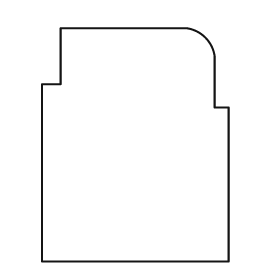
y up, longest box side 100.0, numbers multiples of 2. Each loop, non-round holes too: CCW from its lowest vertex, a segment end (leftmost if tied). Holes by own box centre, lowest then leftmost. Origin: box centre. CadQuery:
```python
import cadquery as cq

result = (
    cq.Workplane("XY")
    .moveTo(-40.0, -50.0)
    .lineTo(40.0, -50.0)
    .lineTo(40.0, 16.0)
    .lineTo(34.0, 16.0)
    .lineTo(34.0, 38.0)
    .threePointArc((30.0, 46.0), (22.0, 50.0))
    .lineTo(-32.0, 50.0)
    .lineTo(-32.0, 26.0)
    .lineTo(-40.0, 26.0)
    .close()
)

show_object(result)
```